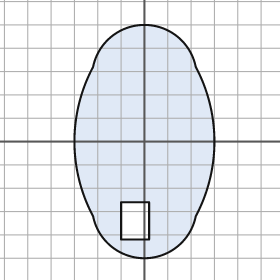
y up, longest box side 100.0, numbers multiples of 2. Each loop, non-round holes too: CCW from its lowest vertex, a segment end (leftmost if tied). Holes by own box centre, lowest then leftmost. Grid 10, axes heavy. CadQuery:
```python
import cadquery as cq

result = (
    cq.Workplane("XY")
    .moveTo(-22.0, -32.0)
    .threePointArc((0.0, -50.0), (22.0, -32.0))
    .threePointArc((30.0, 0.0), (22.0, 32.0))
    .threePointArc((0.0, 50.0), (-22.0, 32.0))
    .threePointArc((-30.0, 0.0), (-22.0, -32.0))
    .close()
    .moveTo(-10.0, -42.0)
    .lineTo(2.0, -42.0)
    .lineTo(2.0, -26.0)
    .lineTo(-10.0, -26.0)
    .close()
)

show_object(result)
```